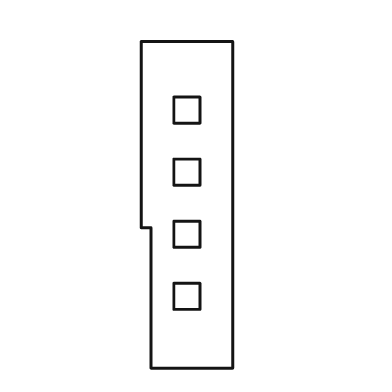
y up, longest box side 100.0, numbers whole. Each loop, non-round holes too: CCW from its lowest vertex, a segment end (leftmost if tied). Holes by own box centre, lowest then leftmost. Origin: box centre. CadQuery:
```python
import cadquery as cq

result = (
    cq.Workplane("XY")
    .moveTo(-11.0, -50.0)
    .lineTo(14.0, -50.0)
    .lineTo(14.0, 50.0)
    .lineTo(-14.0, 50.0)
    .lineTo(-14.0, -7.0)
    .lineTo(-11.0, -7.0)
    .close()
    .moveTo(-4.0, -32.0)
    .lineTo(4.0, -32.0)
    .lineTo(4.0, -24.0)
    .lineTo(-4.0, -24.0)
    .close()
    .moveTo(-4.0, -13.0)
    .lineTo(4.0, -13.0)
    .lineTo(4.0, -5.0)
    .lineTo(-4.0, -5.0)
    .close()
    .moveTo(-4.0, 6.0)
    .lineTo(4.0, 6.0)
    .lineTo(4.0, 14.0)
    .lineTo(-4.0, 14.0)
    .close()
    .moveTo(-4.0, 25.0)
    .lineTo(4.0, 25.0)
    .lineTo(4.0, 33.0)
    .lineTo(-4.0, 33.0)
    .close()
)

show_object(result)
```